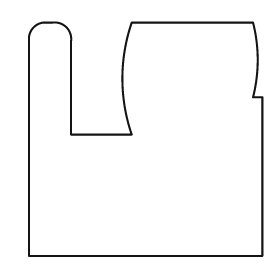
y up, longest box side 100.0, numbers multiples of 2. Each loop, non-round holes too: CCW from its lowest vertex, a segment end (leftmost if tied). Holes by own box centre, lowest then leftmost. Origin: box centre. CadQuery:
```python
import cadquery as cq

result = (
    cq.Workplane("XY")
    .moveTo(-50.0, -50.0)
    .lineTo(50.0, -50.0)
    .lineTo(50.0, 18.0)
    .lineTo(46.0, 18.0)
    .threePointArc((48.0, 34.0), (46.0, 50.0))
    .lineTo(-6.0, 50.0)
    .threePointArc((-10.0, 26.0), (-6.0, 2.0))
    .lineTo(-32.0, 2.0)
    .lineTo(-32.0, 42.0)
    .threePointArc((-34.0, 48.0), (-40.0, 50.0))
    .lineTo(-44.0, 50.0)
    .threePointArc((-48.0, 48.0), (-50.0, 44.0))
    .close()
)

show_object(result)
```